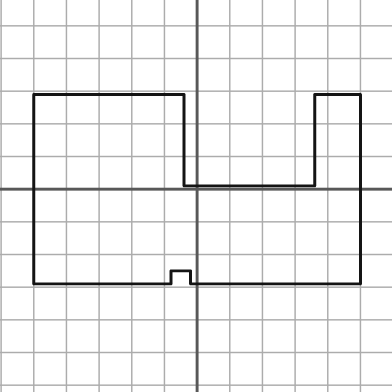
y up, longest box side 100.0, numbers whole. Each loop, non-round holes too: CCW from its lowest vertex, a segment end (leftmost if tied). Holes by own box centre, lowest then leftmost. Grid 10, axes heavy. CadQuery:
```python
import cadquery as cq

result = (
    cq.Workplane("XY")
    .moveTo(-50.0, -29.0)
    .lineTo(-8.0, -29.0)
    .lineTo(-8.0, -25.0)
    .lineTo(-2.0, -25.0)
    .lineTo(-2.0, -29.0)
    .lineTo(50.0, -29.0)
    .lineTo(50.0, 29.0)
    .lineTo(36.0, 29.0)
    .lineTo(36.0, 1.0)
    .lineTo(-4.0, 1.0)
    .lineTo(-4.0, 29.0)
    .lineTo(-50.0, 29.0)
    .close()
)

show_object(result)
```